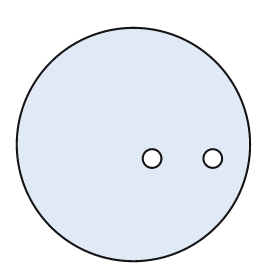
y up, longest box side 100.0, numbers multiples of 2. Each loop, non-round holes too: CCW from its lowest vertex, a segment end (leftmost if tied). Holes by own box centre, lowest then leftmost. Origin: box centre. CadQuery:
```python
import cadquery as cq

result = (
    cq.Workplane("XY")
    .moveTo(0.0, 0.0)
    .circle(50.0)
    .moveTo(8.0, -6.0)
    .circle(4.0)
    .moveTo(34.0, -6.0)
    .circle(4.0)
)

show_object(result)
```